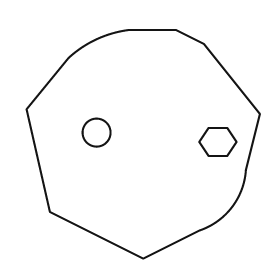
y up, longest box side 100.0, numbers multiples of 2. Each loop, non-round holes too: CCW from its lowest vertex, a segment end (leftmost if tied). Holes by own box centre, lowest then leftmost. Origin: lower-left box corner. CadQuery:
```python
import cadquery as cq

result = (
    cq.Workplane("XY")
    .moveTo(50.0, 0.0)
    .lineTo(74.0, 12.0)
    .threePointArc((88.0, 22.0), (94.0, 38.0))
    .lineTo(100.0, 62.0)
    .lineTo(76.0, 92.0)
    .lineTo(64.0, 98.0)
    .lineTo(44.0, 98.0)
    .threePointArc((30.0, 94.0), (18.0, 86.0))
    .lineTo(0.0, 64.0)
    .lineTo(10.0, 20.0)
    .close()
    .moveTo(78.0, 44.0)
    .lineTo(86.0, 44.0)
    .lineTo(90.0, 50.0)
    .lineTo(86.0, 56.0)
    .lineTo(78.0, 56.0)
    .lineTo(74.0, 50.0)
    .close()
    .moveTo(30.0, 54.0)
    .circle(6.0)
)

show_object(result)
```